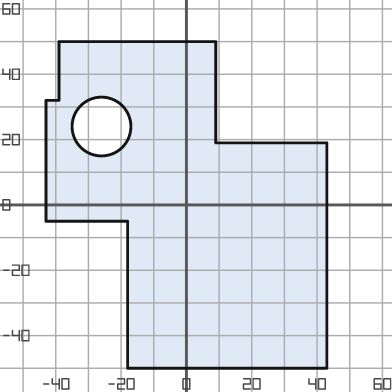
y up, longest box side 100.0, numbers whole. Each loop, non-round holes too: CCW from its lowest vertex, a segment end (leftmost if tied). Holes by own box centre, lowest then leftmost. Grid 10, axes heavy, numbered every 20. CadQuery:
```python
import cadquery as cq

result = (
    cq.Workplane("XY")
    .moveTo(-18.0, -50.0)
    .lineTo(43.0, -50.0)
    .lineTo(43.0, 19.0)
    .lineTo(9.0, 19.0)
    .lineTo(9.0, 50.0)
    .lineTo(-39.0, 50.0)
    .lineTo(-39.0, 32.0)
    .lineTo(-43.0, 32.0)
    .lineTo(-43.0, -5.0)
    .lineTo(-18.0, -5.0)
    .close()
    .moveTo(-26.0, 24.0)
    .circle(9.0)
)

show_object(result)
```